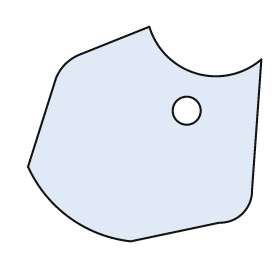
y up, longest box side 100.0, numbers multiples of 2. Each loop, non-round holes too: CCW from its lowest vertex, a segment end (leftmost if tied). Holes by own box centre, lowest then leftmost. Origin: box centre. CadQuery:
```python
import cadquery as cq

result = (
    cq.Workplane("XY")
    .moveTo(-6.0, -46.0)
    .lineTo(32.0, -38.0)
    .threePointArc((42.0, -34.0), (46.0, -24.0))
    .lineTo(50.0, 32.0)
    .threePointArc((22.0, 26.0), (2.0, 46.0))
    .lineTo(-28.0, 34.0)
    .threePointArc((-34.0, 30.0), (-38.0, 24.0))
    .lineTo(-50.0, -14.0)
    .threePointArc((-32.0, -36.0), (-6.0, -46.0))
    .close()
    .moveTo(18.0, 10.0)
    .circle(6.0)
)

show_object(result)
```